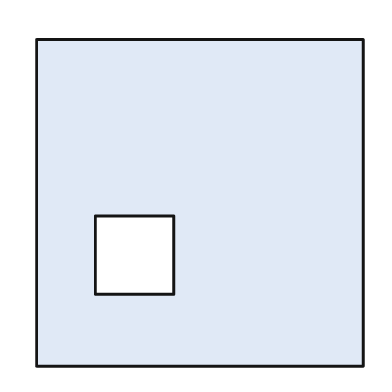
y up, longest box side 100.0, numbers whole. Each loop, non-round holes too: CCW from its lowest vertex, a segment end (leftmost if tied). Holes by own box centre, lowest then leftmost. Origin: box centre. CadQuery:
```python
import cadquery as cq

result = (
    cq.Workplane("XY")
    .moveTo(-50.0, -50.0)
    .lineTo(50.0, -50.0)
    .lineTo(50.0, 50.0)
    .lineTo(-50.0, 50.0)
    .close()
    .moveTo(-32.0, -28.0)
    .lineTo(-8.0, -28.0)
    .lineTo(-8.0, -4.0)
    .lineTo(-32.0, -4.0)
    .close()
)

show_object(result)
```